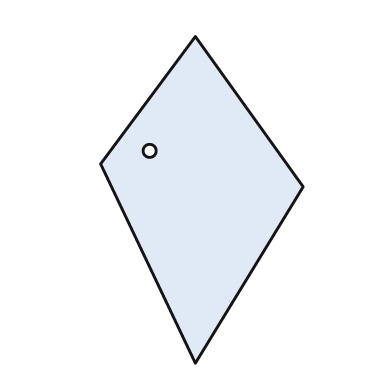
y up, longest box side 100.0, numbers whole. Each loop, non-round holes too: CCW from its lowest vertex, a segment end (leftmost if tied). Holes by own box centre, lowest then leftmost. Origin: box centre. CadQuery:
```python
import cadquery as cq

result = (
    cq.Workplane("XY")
    .moveTo(-2.0, -50.0)
    .lineTo(31.0, 4.0)
    .lineTo(-2.0, 50.0)
    .lineTo(-31.0, 11.0)
    .close()
    .moveTo(-16.0, 15.0)
    .circle(2.0)
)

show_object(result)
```